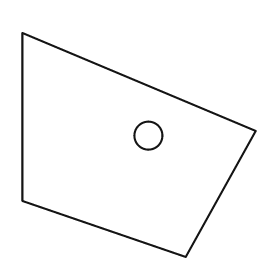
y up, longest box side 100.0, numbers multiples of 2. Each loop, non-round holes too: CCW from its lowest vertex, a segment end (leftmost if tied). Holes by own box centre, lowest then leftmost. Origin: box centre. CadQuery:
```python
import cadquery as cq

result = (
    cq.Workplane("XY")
    .moveTo(20.0, -48.0)
    .lineTo(50.0, 6.0)
    .lineTo(-50.0, 48.0)
    .lineTo(-50.0, -24.0)
    .close()
    .moveTo(4.0, 4.0)
    .circle(6.0)
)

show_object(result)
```